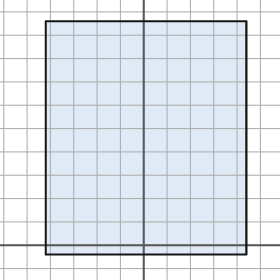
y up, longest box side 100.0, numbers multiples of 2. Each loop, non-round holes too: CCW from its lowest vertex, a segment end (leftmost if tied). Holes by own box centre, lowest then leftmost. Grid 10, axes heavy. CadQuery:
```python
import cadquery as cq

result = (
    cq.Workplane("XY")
    .moveTo(-42.0, -4.0)
    .lineTo(44.0, -4.0)
    .lineTo(44.0, 96.0)
    .lineTo(-42.0, 96.0)
    .close()
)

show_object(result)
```